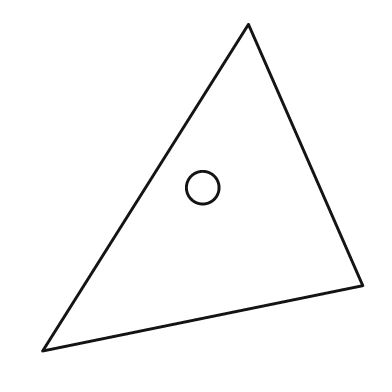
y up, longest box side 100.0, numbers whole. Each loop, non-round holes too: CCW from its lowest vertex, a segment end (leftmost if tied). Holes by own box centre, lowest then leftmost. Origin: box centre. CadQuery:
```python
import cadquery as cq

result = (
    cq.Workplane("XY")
    .moveTo(-49.0, -50.0)
    .lineTo(49.0, -30.0)
    .lineTo(14.0, 50.0)
    .close()
    .moveTo(0.0, 0.0)
    .circle(5.0)
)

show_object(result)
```